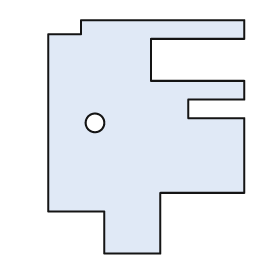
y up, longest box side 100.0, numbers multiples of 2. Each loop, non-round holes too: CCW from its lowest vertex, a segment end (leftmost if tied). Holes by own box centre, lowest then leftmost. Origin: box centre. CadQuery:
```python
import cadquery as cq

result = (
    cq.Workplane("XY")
    .moveTo(-18.0, -50.0)
    .lineTo(6.0, -50.0)
    .lineTo(6.0, -24.0)
    .lineTo(42.0, -24.0)
    .lineTo(42.0, 8.0)
    .lineTo(18.0, 8.0)
    .lineTo(18.0, 16.0)
    .lineTo(42.0, 16.0)
    .lineTo(42.0, 24.0)
    .lineTo(2.0, 24.0)
    .lineTo(2.0, 42.0)
    .lineTo(42.0, 42.0)
    .lineTo(42.0, 50.0)
    .lineTo(-28.0, 50.0)
    .lineTo(-28.0, 44.0)
    .lineTo(-42.0, 44.0)
    .lineTo(-42.0, -32.0)
    .lineTo(-18.0, -32.0)
    .close()
    .moveTo(-22.0, 6.0)
    .circle(4.0)
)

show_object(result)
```